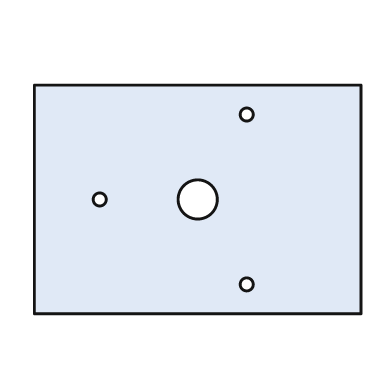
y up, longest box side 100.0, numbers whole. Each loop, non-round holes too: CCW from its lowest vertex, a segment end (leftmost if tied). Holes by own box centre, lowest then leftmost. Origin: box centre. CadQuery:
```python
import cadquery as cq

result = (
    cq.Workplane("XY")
    .moveTo(-50.0, -35.0)
    .lineTo(50.0, -35.0)
    .lineTo(50.0, 35.0)
    .lineTo(-50.0, 35.0)
    .close()
    .moveTo(15.0, -26.0)
    .circle(2.0)
    .moveTo(-30.0, 0.0)
    .circle(2.0)
    .moveTo(0.0, 0.0)
    .circle(6.0)
    .moveTo(15.0, 26.0)
    .circle(2.0)
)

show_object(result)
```